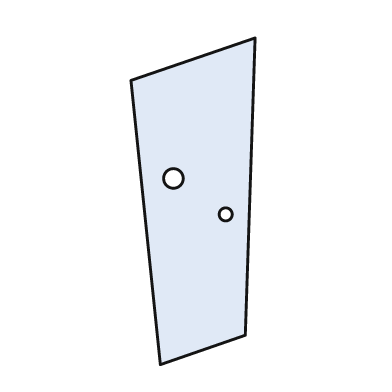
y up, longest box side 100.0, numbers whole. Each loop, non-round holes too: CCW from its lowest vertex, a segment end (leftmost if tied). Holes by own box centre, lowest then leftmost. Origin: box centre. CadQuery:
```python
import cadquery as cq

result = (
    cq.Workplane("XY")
    .moveTo(-10.0, -50.0)
    .lineTo(16.0, -41.0)
    .lineTo(19.0, 50.0)
    .lineTo(-19.0, 37.0)
    .close()
    .moveTo(10.0, -4.0)
    .circle(2.0)
    .moveTo(-6.0, 7.0)
    .circle(3.0)
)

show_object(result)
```